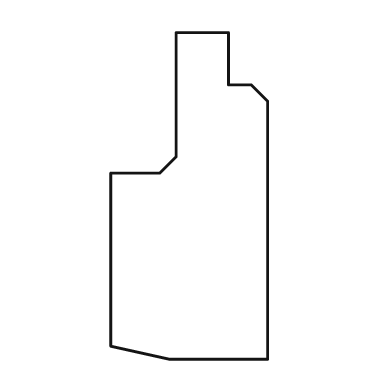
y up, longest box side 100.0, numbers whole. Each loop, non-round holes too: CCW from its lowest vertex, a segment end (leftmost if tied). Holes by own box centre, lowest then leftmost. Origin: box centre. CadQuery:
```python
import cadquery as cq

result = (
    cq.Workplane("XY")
    .moveTo(-6.0, -50.0)
    .lineTo(24.0, -50.0)
    .lineTo(24.0, 29.0)
    .lineTo(19.0, 34.0)
    .lineTo(12.0, 34.0)
    .lineTo(12.0, 50.0)
    .lineTo(-4.0, 50.0)
    .lineTo(-4.0, 12.0)
    .lineTo(-9.0, 7.0)
    .lineTo(-24.0, 7.0)
    .lineTo(-24.0, -46.0)
    .close()
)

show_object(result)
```